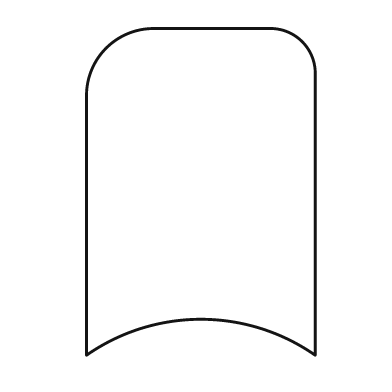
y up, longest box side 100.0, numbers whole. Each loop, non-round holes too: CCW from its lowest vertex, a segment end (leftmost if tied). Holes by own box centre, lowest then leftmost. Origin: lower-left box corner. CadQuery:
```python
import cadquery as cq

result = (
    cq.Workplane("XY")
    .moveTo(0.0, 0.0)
    .threePointArc((35.0, 11.0), (70.0, 0.0))
    .lineTo(70.0, 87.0)
    .threePointArc((66.0, 96.0), (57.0, 100.0))
    .lineTo(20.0, 100.0)
    .threePointArc((6.0, 94.0), (0.0, 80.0))
    .close()
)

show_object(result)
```